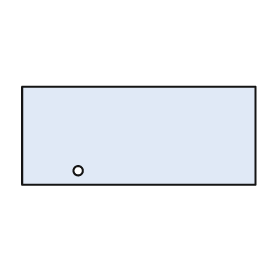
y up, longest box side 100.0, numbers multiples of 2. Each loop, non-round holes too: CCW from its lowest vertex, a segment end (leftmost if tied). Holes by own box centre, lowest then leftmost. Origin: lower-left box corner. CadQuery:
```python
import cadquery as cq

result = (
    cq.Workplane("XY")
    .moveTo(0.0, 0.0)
    .lineTo(100.0, 0.0)
    .lineTo(100.0, 42.0)
    .lineTo(0.0, 42.0)
    .close()
    .moveTo(24.0, 6.0)
    .circle(2.0)
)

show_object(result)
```